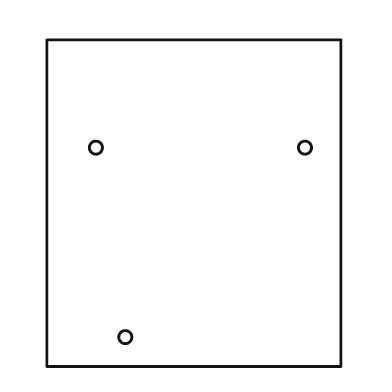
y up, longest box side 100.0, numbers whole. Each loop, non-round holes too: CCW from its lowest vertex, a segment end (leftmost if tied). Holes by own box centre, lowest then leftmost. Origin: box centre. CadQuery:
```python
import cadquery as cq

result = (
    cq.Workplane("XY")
    .moveTo(-45.0, -50.0)
    .lineTo(45.0, -50.0)
    .lineTo(45.0, 50.0)
    .lineTo(-45.0, 50.0)
    .close()
    .moveTo(-21.0, -41.0)
    .circle(2.0)
    .moveTo(-30.0, 17.0)
    .circle(2.0)
    .moveTo(34.0, 17.0)
    .circle(2.0)
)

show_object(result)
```